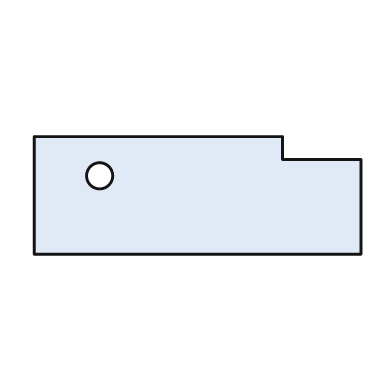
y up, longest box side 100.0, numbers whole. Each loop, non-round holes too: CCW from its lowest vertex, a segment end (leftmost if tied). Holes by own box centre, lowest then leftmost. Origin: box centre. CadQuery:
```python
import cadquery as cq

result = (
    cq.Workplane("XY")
    .moveTo(-50.0, -18.0)
    .lineTo(50.0, -18.0)
    .lineTo(50.0, 11.0)
    .lineTo(26.0, 11.0)
    .lineTo(26.0, 18.0)
    .lineTo(-50.0, 18.0)
    .close()
    .moveTo(-30.0, 6.0)
    .circle(4.0)
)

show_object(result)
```